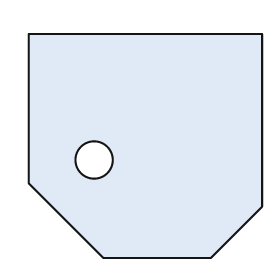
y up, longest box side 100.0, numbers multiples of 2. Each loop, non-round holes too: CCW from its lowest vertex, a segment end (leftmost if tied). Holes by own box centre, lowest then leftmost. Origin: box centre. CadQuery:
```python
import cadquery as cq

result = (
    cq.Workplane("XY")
    .moveTo(-18.0, -48.0)
    .lineTo(28.0, -48.0)
    .lineTo(50.0, -26.0)
    .lineTo(50.0, 48.0)
    .lineTo(-50.0, 48.0)
    .lineTo(-50.0, -16.0)
    .close()
    .moveTo(-22.0, -6.0)
    .circle(8.0)
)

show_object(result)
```